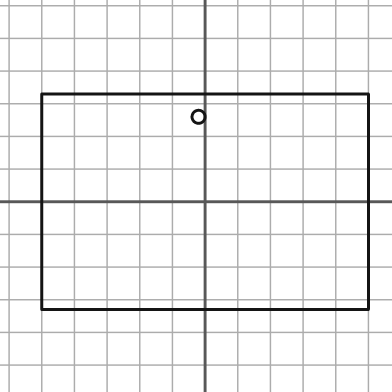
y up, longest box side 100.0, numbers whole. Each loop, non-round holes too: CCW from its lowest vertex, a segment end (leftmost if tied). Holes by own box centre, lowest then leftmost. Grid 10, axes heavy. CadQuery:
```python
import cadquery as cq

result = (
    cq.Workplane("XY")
    .moveTo(-50.0, -33.0)
    .lineTo(50.0, -33.0)
    .lineTo(50.0, 33.0)
    .lineTo(-50.0, 33.0)
    .close()
    .moveTo(-2.0, 26.0)
    .circle(2.0)
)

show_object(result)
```